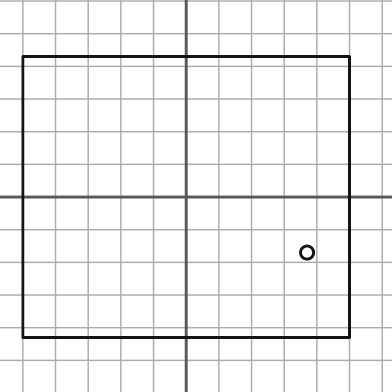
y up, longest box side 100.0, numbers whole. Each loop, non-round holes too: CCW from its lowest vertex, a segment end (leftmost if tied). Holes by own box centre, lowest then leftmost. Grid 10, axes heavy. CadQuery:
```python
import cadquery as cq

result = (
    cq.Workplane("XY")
    .moveTo(-50.0, -43.0)
    .lineTo(50.0, -43.0)
    .lineTo(50.0, 43.0)
    .lineTo(-50.0, 43.0)
    .close()
    .moveTo(37.0, -17.0)
    .circle(2.0)
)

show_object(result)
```